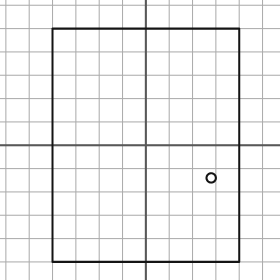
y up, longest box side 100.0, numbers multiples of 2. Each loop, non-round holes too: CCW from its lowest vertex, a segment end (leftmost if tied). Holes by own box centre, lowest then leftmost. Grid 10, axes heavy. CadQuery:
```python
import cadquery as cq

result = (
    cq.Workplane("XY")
    .moveTo(-40.0, -50.0)
    .lineTo(40.0, -50.0)
    .lineTo(40.0, 50.0)
    .lineTo(-40.0, 50.0)
    .close()
    .moveTo(28.0, -14.0)
    .circle(2.0)
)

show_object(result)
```